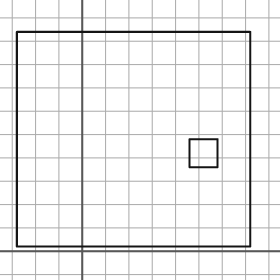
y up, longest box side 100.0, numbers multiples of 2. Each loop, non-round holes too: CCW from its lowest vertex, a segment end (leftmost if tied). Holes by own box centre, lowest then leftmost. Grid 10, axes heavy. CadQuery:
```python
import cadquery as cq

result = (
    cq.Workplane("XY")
    .moveTo(-28.0, 2.0)
    .lineTo(72.0, 2.0)
    .lineTo(72.0, 94.0)
    .lineTo(-28.0, 94.0)
    .close()
    .moveTo(46.0, 36.0)
    .lineTo(58.0, 36.0)
    .lineTo(58.0, 48.0)
    .lineTo(46.0, 48.0)
    .close()
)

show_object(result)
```